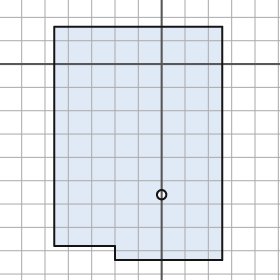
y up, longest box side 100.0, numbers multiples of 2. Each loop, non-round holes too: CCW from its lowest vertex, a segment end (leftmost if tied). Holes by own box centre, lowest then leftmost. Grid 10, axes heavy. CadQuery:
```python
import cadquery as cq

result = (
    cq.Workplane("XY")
    .moveTo(-20.0, -84.0)
    .lineTo(26.0, -84.0)
    .lineTo(26.0, 16.0)
    .lineTo(-46.0, 16.0)
    .lineTo(-46.0, -78.0)
    .lineTo(-20.0, -78.0)
    .close()
    .moveTo(0.0, -56.0)
    .circle(2.0)
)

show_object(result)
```